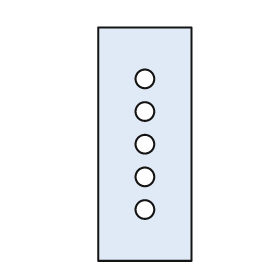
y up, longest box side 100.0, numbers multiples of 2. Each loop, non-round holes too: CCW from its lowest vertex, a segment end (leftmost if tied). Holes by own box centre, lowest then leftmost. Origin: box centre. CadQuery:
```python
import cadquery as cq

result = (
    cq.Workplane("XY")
    .moveTo(-20.0, -50.0)
    .lineTo(20.0, -50.0)
    .lineTo(20.0, 50.0)
    .lineTo(-20.0, 50.0)
    .close()
    .moveTo(0.0, -28.0)
    .circle(4.0)
    .moveTo(0.0, -14.0)
    .circle(4.0)
    .moveTo(0.0, 0.0)
    .circle(4.0)
    .moveTo(0.0, 14.0)
    .circle(4.0)
    .moveTo(0.0, 28.0)
    .circle(4.0)
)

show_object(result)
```